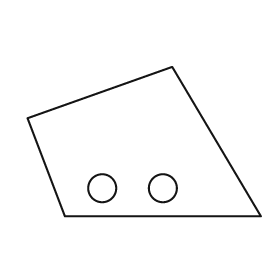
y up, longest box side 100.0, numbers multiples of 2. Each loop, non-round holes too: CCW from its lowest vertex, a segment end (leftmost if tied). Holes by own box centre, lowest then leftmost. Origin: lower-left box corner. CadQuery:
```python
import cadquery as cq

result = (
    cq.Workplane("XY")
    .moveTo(16.0, 0.0)
    .lineTo(100.0, 0.0)
    .lineTo(62.0, 64.0)
    .lineTo(0.0, 42.0)
    .close()
    .moveTo(32.0, 12.0)
    .circle(6.0)
    .moveTo(58.0, 12.0)
    .circle(6.0)
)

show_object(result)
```